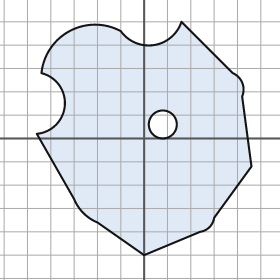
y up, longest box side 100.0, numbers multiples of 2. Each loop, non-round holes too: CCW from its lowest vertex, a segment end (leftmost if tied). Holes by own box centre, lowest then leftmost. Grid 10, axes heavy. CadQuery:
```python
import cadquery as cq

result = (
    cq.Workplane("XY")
    .moveTo(0.0, -50.0)
    .lineTo(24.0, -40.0)
    .threePointArc((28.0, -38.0), (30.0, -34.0))
    .lineTo(46.0, -12.0)
    .lineTo(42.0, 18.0)
    .threePointArc((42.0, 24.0), (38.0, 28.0))
    .lineTo(16.0, 50.0)
    .threePointArc((4.0, 40.0), (-10.0, 46.0))
    .threePointArc((-32.0, 46.0), (-44.0, 28.0))
    .threePointArc((-34.0, 14.0), (-46.0, 2.0))
    .lineTo(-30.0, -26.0)
    .threePointArc((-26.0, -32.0), (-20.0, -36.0))
    .close()
    .moveTo(8.0, 6.0)
    .circle(6.0)
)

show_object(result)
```